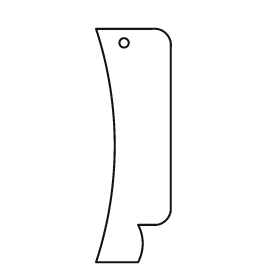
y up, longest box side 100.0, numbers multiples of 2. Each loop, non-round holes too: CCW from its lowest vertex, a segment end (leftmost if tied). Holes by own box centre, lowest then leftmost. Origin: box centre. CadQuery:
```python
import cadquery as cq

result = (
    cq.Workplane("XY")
    .moveTo(-16.0, -50.0)
    .lineTo(2.0, -50.0)
    .threePointArc((4.0, -42.0), (2.0, -34.0))
    .lineTo(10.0, -34.0)
    .threePointArc((14.0, -32.0), (16.0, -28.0))
    .lineTo(16.0, 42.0)
    .threePointArc((14.0, 48.0), (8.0, 50.0))
    .lineTo(-16.0, 50.0)
    .threePointArc((-8.0, 0.0), (-16.0, -50.0))
    .close()
    .moveTo(-4.0, 44.0)
    .circle(2.0)
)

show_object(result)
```